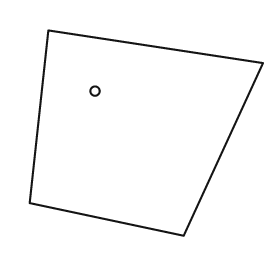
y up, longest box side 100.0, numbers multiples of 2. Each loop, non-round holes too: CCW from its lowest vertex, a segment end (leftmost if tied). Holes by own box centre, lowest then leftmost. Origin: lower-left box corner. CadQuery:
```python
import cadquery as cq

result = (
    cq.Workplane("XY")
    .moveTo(66.0, 0.0)
    .lineTo(100.0, 74.0)
    .lineTo(8.0, 88.0)
    .lineTo(0.0, 14.0)
    .close()
    .moveTo(28.0, 62.0)
    .circle(2.0)
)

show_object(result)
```